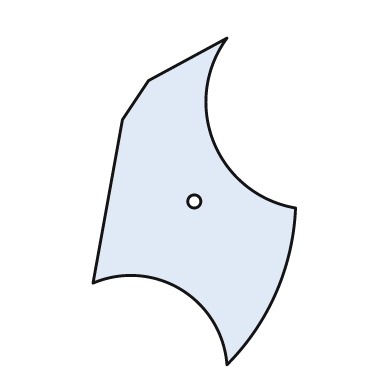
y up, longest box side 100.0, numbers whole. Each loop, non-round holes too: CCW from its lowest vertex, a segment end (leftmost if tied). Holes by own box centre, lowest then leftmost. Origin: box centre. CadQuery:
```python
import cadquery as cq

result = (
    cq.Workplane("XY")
    .moveTo(10.0, -50.0)
    .threePointArc((25.0, -28.0), (31.0, -2.0))
    .threePointArc((6.0, 18.0), (10.0, 50.0))
    .lineTo(-14.0, 37.0)
    .lineTo(-22.0, 25.0)
    .lineTo(-31.0, -25.0)
    .threePointArc((-4.0, -27.0), (10.0, -50.0))
    .close()
    .moveTo(0.0, 0.0)
    .circle(2.0)
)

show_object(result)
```